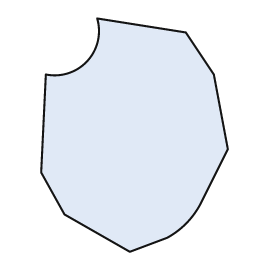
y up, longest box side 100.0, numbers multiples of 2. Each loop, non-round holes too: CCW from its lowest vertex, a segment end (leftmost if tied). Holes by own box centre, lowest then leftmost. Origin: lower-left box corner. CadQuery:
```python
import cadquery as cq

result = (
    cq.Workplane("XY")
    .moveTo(38.0, 0.0)
    .lineTo(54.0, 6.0)
    .threePointArc((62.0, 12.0), (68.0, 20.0))
    .lineTo(80.0, 44.0)
    .lineTo(74.0, 76.0)
    .lineTo(62.0, 94.0)
    .lineTo(24.0, 100.0)
    .threePointArc((20.0, 82.0), (2.0, 76.0))
    .lineTo(0.0, 34.0)
    .lineTo(10.0, 16.0)
    .close()
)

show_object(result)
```